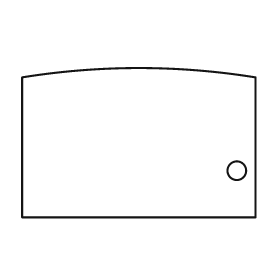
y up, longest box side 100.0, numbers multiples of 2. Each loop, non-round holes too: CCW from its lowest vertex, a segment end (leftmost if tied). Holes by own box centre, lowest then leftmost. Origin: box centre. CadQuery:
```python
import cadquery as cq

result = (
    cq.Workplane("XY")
    .moveTo(-50.0, -32.0)
    .lineTo(50.0, -32.0)
    .lineTo(50.0, 28.0)
    .threePointArc((0.0, 32.0), (-50.0, 28.0))
    .close()
    .moveTo(42.0, -12.0)
    .circle(4.0)
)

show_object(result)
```